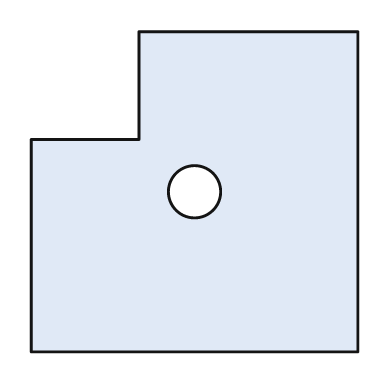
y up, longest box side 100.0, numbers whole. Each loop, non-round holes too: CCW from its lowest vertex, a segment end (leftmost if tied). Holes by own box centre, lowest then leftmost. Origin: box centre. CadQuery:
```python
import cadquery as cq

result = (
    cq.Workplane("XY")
    .moveTo(-50.0, -49.0)
    .lineTo(50.0, -49.0)
    .lineTo(50.0, 49.0)
    .lineTo(-17.0, 49.0)
    .lineTo(-17.0, 16.0)
    .lineTo(-50.0, 16.0)
    .close()
    .moveTo(0.0, 0.0)
    .circle(8.0)
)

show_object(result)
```